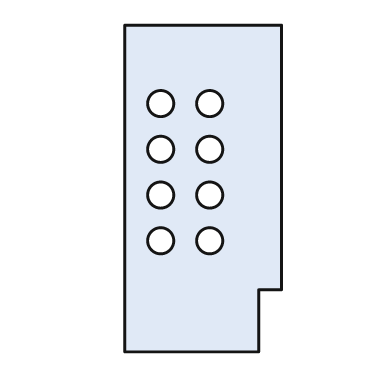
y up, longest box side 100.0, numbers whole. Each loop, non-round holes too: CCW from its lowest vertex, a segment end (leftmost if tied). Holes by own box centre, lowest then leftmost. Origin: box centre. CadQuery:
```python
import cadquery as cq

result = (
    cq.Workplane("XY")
    .moveTo(-24.0, -50.0)
    .lineTo(17.0, -50.0)
    .lineTo(17.0, -31.0)
    .lineTo(24.0, -31.0)
    .lineTo(24.0, 50.0)
    .lineTo(-24.0, 50.0)
    .close()
    .moveTo(-13.0, -16.0)
    .circle(4.0)
    .moveTo(2.0, -16.0)
    .circle(4.0)
    .moveTo(-13.0, -2.0)
    .circle(4.0)
    .moveTo(2.0, -2.0)
    .circle(4.0)
    .moveTo(-13.0, 12.0)
    .circle(4.0)
    .moveTo(2.0, 12.0)
    .circle(4.0)
    .moveTo(-13.0, 26.0)
    .circle(4.0)
    .moveTo(2.0, 26.0)
    .circle(4.0)
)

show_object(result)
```